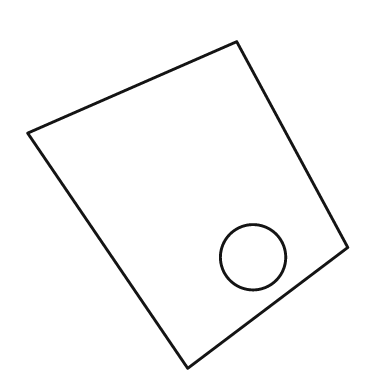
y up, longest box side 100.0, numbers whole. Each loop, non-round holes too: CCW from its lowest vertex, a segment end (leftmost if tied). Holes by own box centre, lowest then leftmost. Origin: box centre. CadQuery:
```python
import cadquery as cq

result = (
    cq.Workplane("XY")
    .moveTo(0.0, -50.0)
    .lineTo(49.0, -13.0)
    .lineTo(15.0, 50.0)
    .lineTo(-49.0, 22.0)
    .close()
    .moveTo(20.0, -16.0)
    .circle(10.0)
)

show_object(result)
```